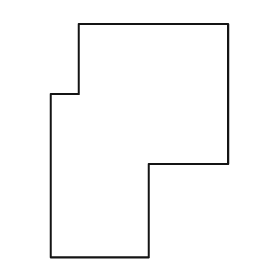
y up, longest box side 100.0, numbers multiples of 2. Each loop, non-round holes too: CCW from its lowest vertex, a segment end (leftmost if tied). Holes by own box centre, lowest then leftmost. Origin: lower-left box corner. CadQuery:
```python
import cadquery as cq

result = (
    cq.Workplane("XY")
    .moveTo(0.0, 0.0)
    .lineTo(42.0, 0.0)
    .lineTo(42.0, 40.0)
    .lineTo(76.0, 40.0)
    .lineTo(76.0, 100.0)
    .lineTo(12.0, 100.0)
    .lineTo(12.0, 70.0)
    .lineTo(0.0, 70.0)
    .close()
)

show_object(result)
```